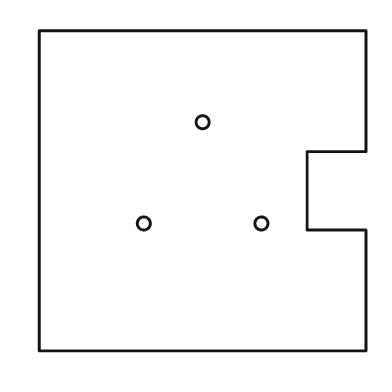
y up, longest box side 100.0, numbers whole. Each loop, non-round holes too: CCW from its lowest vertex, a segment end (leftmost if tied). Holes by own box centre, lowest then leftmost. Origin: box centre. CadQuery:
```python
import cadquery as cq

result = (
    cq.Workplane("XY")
    .moveTo(-50.0, -49.0)
    .lineTo(50.0, -49.0)
    .lineTo(50.0, -12.0)
    .lineTo(32.0, -12.0)
    .lineTo(32.0, 12.0)
    .lineTo(50.0, 12.0)
    .lineTo(50.0, 49.0)
    .lineTo(-50.0, 49.0)
    .close()
    .moveTo(-18.0, -10.0)
    .circle(2.0)
    .moveTo(18.0, -10.0)
    .circle(2.0)
    .moveTo(0.0, 21.0)
    .circle(2.0)
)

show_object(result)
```